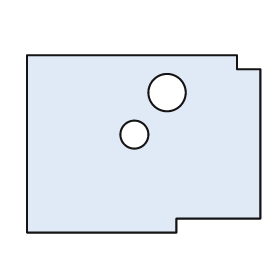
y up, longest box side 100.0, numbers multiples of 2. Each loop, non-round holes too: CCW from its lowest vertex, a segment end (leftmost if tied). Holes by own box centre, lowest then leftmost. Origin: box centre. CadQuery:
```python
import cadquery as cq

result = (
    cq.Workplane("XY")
    .moveTo(-50.0, -38.0)
    .lineTo(14.0, -38.0)
    .lineTo(14.0, -32.0)
    .lineTo(50.0, -32.0)
    .lineTo(50.0, 32.0)
    .lineTo(40.0, 32.0)
    .lineTo(40.0, 38.0)
    .lineTo(-50.0, 38.0)
    .close()
    .moveTo(-4.0, 4.0)
    .circle(6.0)
    .moveTo(10.0, 22.0)
    .circle(8.0)
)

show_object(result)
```